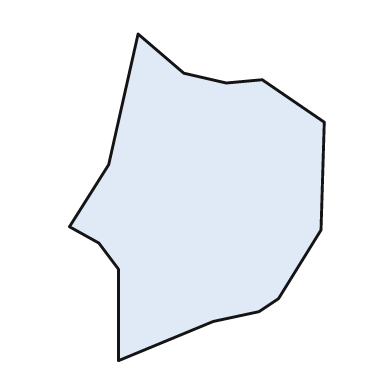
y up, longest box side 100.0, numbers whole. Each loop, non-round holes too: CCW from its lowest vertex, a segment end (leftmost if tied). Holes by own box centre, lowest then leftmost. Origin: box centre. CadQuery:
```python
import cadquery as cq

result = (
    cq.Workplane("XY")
    .moveTo(-24.0, -50.0)
    .lineTo(5.0, -38.0)
    .lineTo(19.0, -35.0)
    .lineTo(25.0, -31.0)
    .lineTo(38.0, -10.0)
    .lineTo(39.0, 23.0)
    .lineTo(20.0, 36.0)
    .lineTo(9.0, 35.0)
    .lineTo(-4.0, 38.0)
    .lineTo(-18.0, 50.0)
    .lineTo(-27.0, 10.0)
    .lineTo(-39.0, -9.0)
    .lineTo(-30.0, -14.0)
    .lineTo(-24.0, -22.0)
    .close()
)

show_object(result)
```